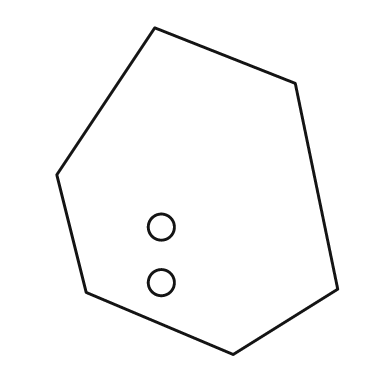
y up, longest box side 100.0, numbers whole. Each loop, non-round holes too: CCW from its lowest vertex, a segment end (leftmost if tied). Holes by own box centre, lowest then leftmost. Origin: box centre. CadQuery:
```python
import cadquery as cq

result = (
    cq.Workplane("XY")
    .moveTo(11.0, -50.0)
    .lineTo(43.0, -30.0)
    .lineTo(30.0, 33.0)
    .lineTo(-13.0, 50.0)
    .lineTo(-43.0, 5.0)
    .lineTo(-34.0, -31.0)
    .close()
    .moveTo(-11.0, -28.0)
    .circle(4.0)
    .moveTo(-11.0, -11.0)
    .circle(4.0)
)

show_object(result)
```